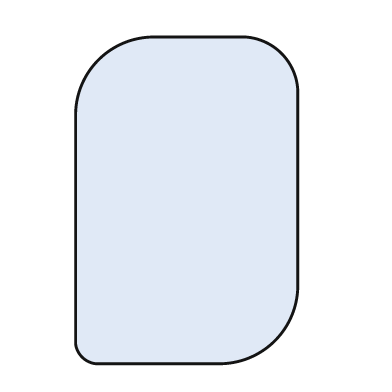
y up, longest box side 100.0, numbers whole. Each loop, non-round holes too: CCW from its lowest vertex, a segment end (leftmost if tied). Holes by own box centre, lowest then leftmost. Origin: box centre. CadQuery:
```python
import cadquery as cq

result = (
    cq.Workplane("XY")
    .moveTo(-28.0, -50.0)
    .lineTo(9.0, -50.0)
    .threePointArc((27.0, -43.0), (34.0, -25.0))
    .lineTo(34.0, 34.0)
    .threePointArc((29.0, 45.0), (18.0, 50.0))
    .lineTo(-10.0, 50.0)
    .threePointArc((-27.0, 43.0), (-34.0, 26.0))
    .lineTo(-34.0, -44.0)
    .threePointArc((-32.0, -48.0), (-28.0, -50.0))
    .close()
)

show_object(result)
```